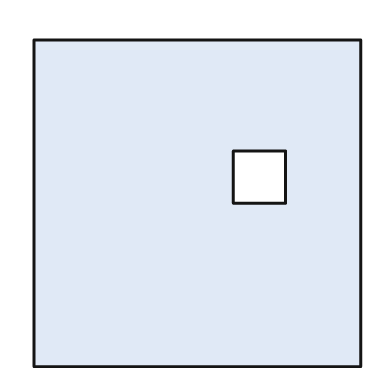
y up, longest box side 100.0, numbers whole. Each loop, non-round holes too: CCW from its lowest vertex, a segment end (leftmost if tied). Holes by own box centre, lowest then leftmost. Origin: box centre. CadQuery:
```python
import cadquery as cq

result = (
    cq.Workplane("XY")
    .moveTo(-50.0, -50.0)
    .lineTo(50.0, -50.0)
    .lineTo(50.0, 50.0)
    .lineTo(-50.0, 50.0)
    .close()
    .moveTo(11.0, 0.0)
    .lineTo(27.0, 0.0)
    .lineTo(27.0, 16.0)
    .lineTo(11.0, 16.0)
    .close()
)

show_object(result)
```